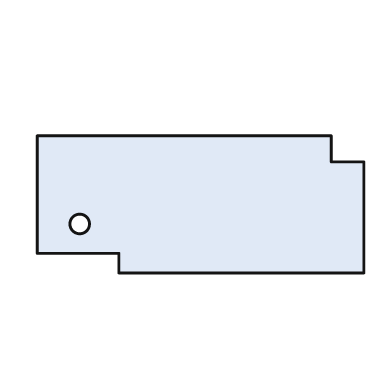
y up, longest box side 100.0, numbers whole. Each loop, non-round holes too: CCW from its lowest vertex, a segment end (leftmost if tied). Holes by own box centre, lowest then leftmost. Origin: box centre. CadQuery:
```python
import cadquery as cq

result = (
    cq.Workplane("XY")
    .moveTo(-25.0, -21.0)
    .lineTo(50.0, -21.0)
    .lineTo(50.0, 13.0)
    .lineTo(40.0, 13.0)
    .lineTo(40.0, 21.0)
    .lineTo(-50.0, 21.0)
    .lineTo(-50.0, -15.0)
    .lineTo(-25.0, -15.0)
    .close()
    .moveTo(-37.0, -6.0)
    .circle(3.0)
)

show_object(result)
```